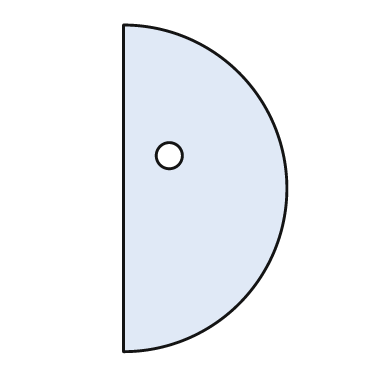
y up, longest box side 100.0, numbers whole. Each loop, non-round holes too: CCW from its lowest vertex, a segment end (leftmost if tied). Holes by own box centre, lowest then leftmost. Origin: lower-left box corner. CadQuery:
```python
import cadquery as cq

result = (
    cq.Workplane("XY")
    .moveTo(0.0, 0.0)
    .threePointArc((50.0, 50.0), (0.0, 100.0))
    .close()
    .moveTo(14.0, 60.0)
    .circle(4.0)
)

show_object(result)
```